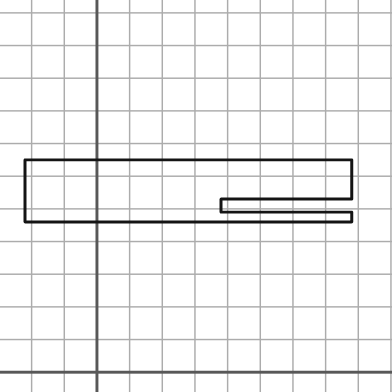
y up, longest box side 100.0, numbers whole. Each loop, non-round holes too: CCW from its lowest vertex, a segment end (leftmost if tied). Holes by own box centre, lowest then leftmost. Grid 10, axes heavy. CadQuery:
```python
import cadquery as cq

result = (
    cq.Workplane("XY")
    .moveTo(-22.0, 46.0)
    .lineTo(78.0, 46.0)
    .lineTo(78.0, 49.0)
    .lineTo(38.0, 49.0)
    .lineTo(38.0, 53.0)
    .lineTo(78.0, 53.0)
    .lineTo(78.0, 65.0)
    .lineTo(-22.0, 65.0)
    .close()
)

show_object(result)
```